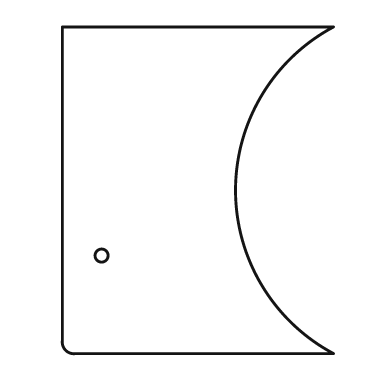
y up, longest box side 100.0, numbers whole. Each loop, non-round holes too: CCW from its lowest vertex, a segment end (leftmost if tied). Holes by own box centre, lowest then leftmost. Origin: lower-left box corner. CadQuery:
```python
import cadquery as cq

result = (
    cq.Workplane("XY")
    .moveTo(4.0, 0.0)
    .lineTo(83.0, 0.0)
    .threePointArc((53.0, 50.0), (83.0, 100.0))
    .lineTo(0.0, 100.0)
    .lineTo(0.0, 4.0)
    .threePointArc((1.0, 1.0), (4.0, 0.0))
    .close()
    .moveTo(12.0, 30.0)
    .circle(2.0)
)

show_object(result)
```